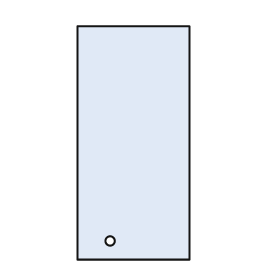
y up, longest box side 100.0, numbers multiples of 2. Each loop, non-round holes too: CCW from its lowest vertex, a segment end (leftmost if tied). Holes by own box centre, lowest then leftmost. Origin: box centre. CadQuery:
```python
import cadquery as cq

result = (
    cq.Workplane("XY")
    .moveTo(-24.0, -50.0)
    .lineTo(24.0, -50.0)
    .lineTo(24.0, 50.0)
    .lineTo(-24.0, 50.0)
    .close()
    .moveTo(-10.0, -42.0)
    .circle(2.0)
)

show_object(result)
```